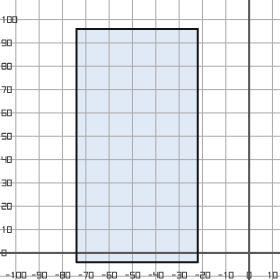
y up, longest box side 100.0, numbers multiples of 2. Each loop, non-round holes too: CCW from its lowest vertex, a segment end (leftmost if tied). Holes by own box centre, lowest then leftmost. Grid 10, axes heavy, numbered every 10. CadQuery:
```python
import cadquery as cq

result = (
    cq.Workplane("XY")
    .moveTo(-74.0, -4.0)
    .lineTo(-22.0, -4.0)
    .lineTo(-22.0, 96.0)
    .lineTo(-74.0, 96.0)
    .close()
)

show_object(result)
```